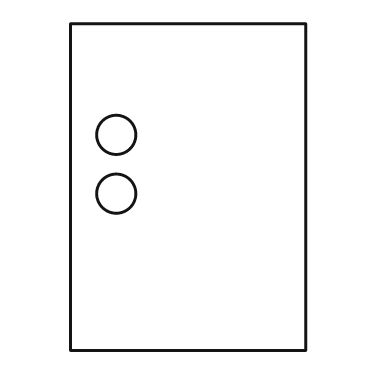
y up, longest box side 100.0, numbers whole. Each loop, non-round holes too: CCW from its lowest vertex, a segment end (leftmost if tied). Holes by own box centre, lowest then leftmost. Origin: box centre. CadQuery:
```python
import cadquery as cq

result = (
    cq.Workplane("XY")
    .moveTo(-36.0, -50.0)
    .lineTo(36.0, -50.0)
    .lineTo(36.0, 50.0)
    .lineTo(-36.0, 50.0)
    .close()
    .moveTo(-22.0, -2.0)
    .circle(6.0)
    .moveTo(-22.0, 16.0)
    .circle(6.0)
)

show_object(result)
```